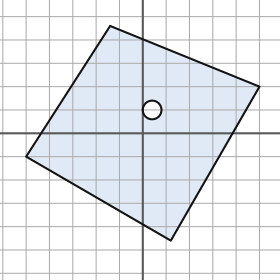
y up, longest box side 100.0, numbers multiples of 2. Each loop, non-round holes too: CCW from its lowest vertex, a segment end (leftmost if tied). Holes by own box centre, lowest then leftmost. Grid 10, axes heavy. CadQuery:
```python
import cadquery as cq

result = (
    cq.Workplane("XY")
    .moveTo(12.0, -46.0)
    .lineTo(50.0, 20.0)
    .lineTo(-14.0, 46.0)
    .lineTo(-50.0, -10.0)
    .close()
    .moveTo(4.0, 10.0)
    .circle(4.0)
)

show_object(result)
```